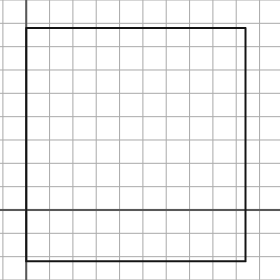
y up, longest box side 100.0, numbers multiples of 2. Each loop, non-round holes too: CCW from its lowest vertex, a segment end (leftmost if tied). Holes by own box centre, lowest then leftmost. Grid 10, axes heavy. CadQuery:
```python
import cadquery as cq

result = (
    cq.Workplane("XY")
    .moveTo(0.0, -22.0)
    .lineTo(94.0, -22.0)
    .lineTo(94.0, 78.0)
    .lineTo(0.0, 78.0)
    .close()
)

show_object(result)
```